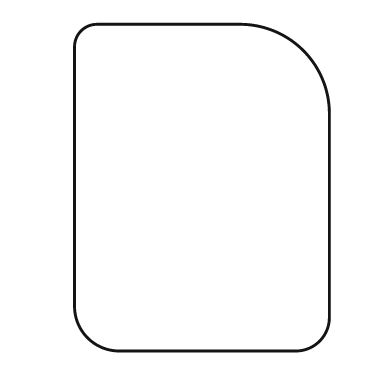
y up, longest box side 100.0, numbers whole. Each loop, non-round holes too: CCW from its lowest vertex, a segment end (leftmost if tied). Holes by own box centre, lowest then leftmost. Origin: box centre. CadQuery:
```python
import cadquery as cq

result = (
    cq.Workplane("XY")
    .moveTo(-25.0, -50.0)
    .lineTo(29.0, -50.0)
    .threePointArc((36.0, -47.0), (39.0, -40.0))
    .lineTo(39.0, 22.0)
    .threePointArc((31.0, 42.0), (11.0, 50.0))
    .lineTo(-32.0, 50.0)
    .threePointArc((-37.0, 48.0), (-39.0, 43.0))
    .lineTo(-39.0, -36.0)
    .threePointArc((-35.0, -46.0), (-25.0, -50.0))
    .close()
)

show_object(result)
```